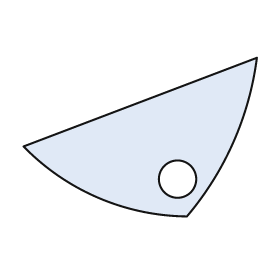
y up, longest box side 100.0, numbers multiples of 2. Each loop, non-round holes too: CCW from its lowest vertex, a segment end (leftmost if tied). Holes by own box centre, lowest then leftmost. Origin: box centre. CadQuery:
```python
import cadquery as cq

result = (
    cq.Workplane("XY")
    .moveTo(20.0, -34.0)
    .threePointArc((40.0, -2.0), (50.0, 34.0))
    .lineTo(-50.0, -4.0)
    .threePointArc((-18.0, -26.0), (20.0, -34.0))
    .close()
    .moveTo(16.0, -18.0)
    .circle(8.0)
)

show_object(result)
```